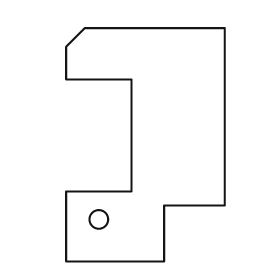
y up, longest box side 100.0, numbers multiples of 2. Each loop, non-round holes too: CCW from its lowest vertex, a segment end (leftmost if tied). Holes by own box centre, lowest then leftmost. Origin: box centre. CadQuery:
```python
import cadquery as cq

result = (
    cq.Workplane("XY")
    .moveTo(-34.0, -50.0)
    .lineTo(8.0, -50.0)
    .lineTo(8.0, -26.0)
    .lineTo(34.0, -26.0)
    .lineTo(34.0, 50.0)
    .lineTo(-26.0, 50.0)
    .lineTo(-34.0, 42.0)
    .lineTo(-34.0, 28.0)
    .lineTo(-6.0, 28.0)
    .lineTo(-6.0, -20.0)
    .lineTo(-34.0, -20.0)
    .close()
    .moveTo(-20.0, -32.0)
    .circle(4.0)
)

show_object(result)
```